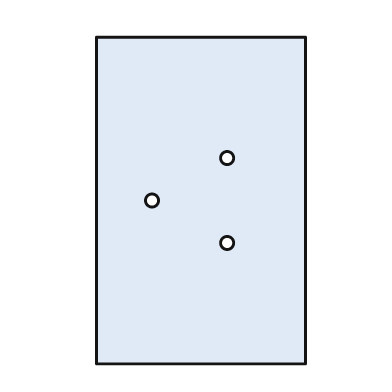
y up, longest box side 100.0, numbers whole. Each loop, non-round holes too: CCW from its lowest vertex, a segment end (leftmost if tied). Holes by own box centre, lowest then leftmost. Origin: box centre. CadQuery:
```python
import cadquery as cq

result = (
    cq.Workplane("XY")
    .moveTo(-32.0, -50.0)
    .lineTo(32.0, -50.0)
    .lineTo(32.0, 50.0)
    .lineTo(-32.0, 50.0)
    .close()
    .moveTo(8.0, -13.0)
    .circle(2.0)
    .moveTo(-15.0, 0.0)
    .circle(2.0)
    .moveTo(8.0, 13.0)
    .circle(2.0)
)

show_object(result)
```